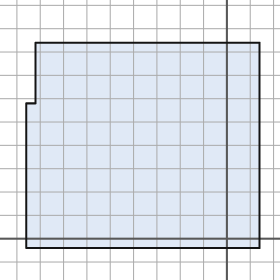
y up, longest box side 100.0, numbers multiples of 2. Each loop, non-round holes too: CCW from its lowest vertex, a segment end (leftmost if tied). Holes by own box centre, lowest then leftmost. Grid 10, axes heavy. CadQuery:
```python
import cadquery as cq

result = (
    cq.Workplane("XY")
    .moveTo(-86.0, -4.0)
    .lineTo(14.0, -4.0)
    .lineTo(14.0, 84.0)
    .lineTo(-82.0, 84.0)
    .lineTo(-82.0, 58.0)
    .lineTo(-86.0, 58.0)
    .close()
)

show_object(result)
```